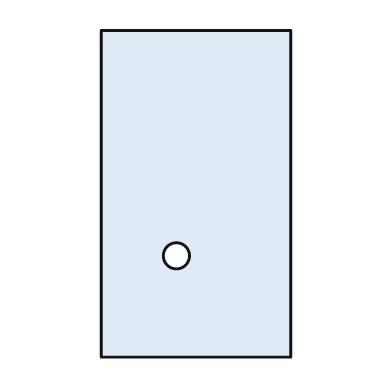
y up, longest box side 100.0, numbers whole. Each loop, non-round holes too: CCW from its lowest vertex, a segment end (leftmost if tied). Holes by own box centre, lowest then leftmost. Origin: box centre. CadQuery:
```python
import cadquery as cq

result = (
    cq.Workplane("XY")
    .moveTo(-29.0, -50.0)
    .lineTo(29.0, -50.0)
    .lineTo(29.0, 50.0)
    .lineTo(-29.0, 50.0)
    .close()
    .moveTo(-6.0, -19.0)
    .circle(4.0)
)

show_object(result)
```